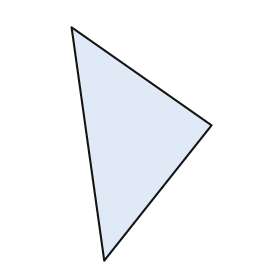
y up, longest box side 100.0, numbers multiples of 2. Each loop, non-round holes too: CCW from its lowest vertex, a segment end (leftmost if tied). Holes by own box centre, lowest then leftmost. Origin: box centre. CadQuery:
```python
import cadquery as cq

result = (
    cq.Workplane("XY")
    .moveTo(-16.0, -50.0)
    .lineTo(30.0, 8.0)
    .lineTo(-30.0, 50.0)
    .close()
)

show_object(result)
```